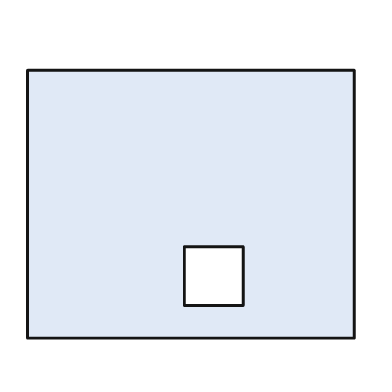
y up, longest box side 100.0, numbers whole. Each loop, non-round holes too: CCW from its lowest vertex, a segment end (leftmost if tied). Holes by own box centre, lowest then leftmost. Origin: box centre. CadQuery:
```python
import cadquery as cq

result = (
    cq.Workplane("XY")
    .moveTo(-50.0, -41.0)
    .lineTo(50.0, -41.0)
    .lineTo(50.0, 41.0)
    .lineTo(-50.0, 41.0)
    .close()
    .moveTo(-2.0, -31.0)
    .lineTo(16.0, -31.0)
    .lineTo(16.0, -13.0)
    .lineTo(-2.0, -13.0)
    .close()
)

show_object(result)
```